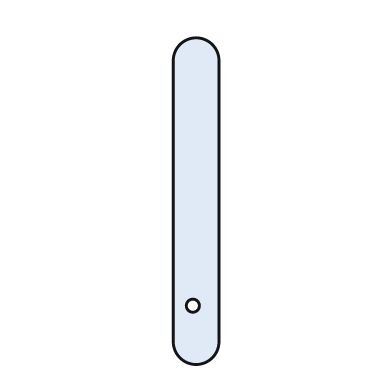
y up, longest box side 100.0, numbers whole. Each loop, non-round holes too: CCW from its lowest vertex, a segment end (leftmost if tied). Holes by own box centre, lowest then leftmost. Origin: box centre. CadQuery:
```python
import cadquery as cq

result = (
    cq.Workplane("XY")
    .moveTo(-7.0, -43.0)
    .threePointArc((0.0, -50.0), (7.0, -43.0))
    .lineTo(7.0, 43.0)
    .threePointArc((0.0, 50.0), (-7.0, 43.0))
    .close()
    .moveTo(-1.0, -32.0)
    .circle(2.0)
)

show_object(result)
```